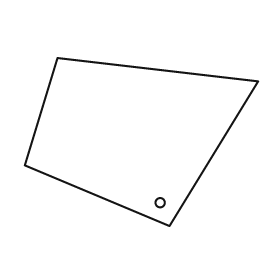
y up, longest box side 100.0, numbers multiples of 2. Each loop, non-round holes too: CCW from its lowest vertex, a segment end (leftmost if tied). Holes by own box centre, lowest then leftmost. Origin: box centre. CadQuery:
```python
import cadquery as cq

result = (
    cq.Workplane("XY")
    .moveTo(12.0, -36.0)
    .lineTo(50.0, 26.0)
    .lineTo(-36.0, 36.0)
    .lineTo(-50.0, -10.0)
    .close()
    .moveTo(8.0, -26.0)
    .circle(2.0)
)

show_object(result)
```